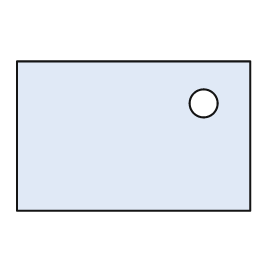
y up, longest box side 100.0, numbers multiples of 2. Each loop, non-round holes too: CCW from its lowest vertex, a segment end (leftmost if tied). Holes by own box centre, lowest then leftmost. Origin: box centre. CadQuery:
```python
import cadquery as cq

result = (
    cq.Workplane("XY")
    .moveTo(-50.0, -32.0)
    .lineTo(50.0, -32.0)
    .lineTo(50.0, 32.0)
    .lineTo(-50.0, 32.0)
    .close()
    .moveTo(30.0, 14.0)
    .circle(6.0)
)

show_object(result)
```